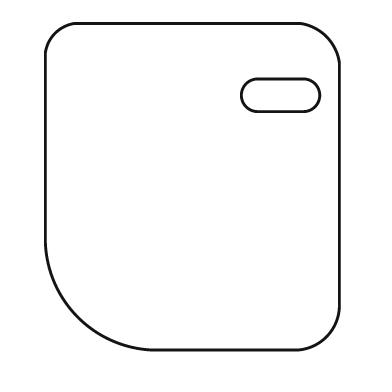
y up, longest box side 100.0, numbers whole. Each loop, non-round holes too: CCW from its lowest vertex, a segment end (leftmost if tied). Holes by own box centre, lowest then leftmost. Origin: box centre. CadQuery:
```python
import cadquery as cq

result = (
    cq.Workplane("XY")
    .moveTo(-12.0, -50.0)
    .lineTo(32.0, -50.0)
    .threePointArc((41.0, -46.0), (45.0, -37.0))
    .lineTo(45.0, 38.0)
    .threePointArc((41.0, 46.0), (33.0, 50.0))
    .lineTo(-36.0, 50.0)
    .threePointArc((-42.0, 47.0), (-45.0, 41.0))
    .lineTo(-45.0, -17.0)
    .threePointArc((-35.0, -40.0), (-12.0, -50.0))
    .close()
    .moveTo(20.0, 23.0)
    .lineTo(34.0, 23.0)
    .threePointArc((39.0, 28.0), (34.0, 33.0))
    .lineTo(20.0, 33.0)
    .threePointArc((15.0, 28.0), (20.0, 23.0))
    .close()
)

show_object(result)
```